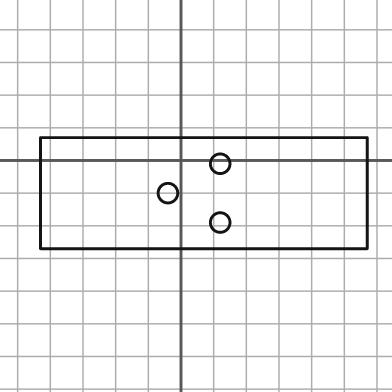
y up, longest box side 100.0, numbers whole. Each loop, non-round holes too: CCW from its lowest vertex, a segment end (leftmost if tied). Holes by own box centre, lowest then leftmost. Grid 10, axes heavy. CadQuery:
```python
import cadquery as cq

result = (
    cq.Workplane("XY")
    .moveTo(-43.0, -27.0)
    .lineTo(57.0, -27.0)
    .lineTo(57.0, 7.0)
    .lineTo(-43.0, 7.0)
    .close()
    .moveTo(12.0, -19.0)
    .circle(3.0)
    .moveTo(-4.0, -10.0)
    .circle(3.0)
    .moveTo(12.0, -1.0)
    .circle(3.0)
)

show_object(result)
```